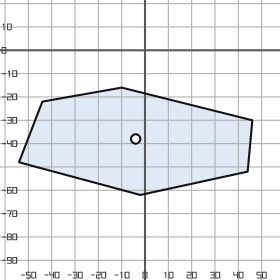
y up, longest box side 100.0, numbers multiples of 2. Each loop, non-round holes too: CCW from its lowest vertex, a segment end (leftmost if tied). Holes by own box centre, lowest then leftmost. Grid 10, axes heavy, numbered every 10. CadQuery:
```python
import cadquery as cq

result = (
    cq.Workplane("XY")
    .moveTo(-2.0, -62.0)
    .lineTo(44.0, -52.0)
    .lineTo(46.0, -30.0)
    .lineTo(-10.0, -16.0)
    .lineTo(-44.0, -22.0)
    .lineTo(-54.0, -48.0)
    .close()
    .moveTo(-4.0, -38.0)
    .circle(2.0)
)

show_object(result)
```